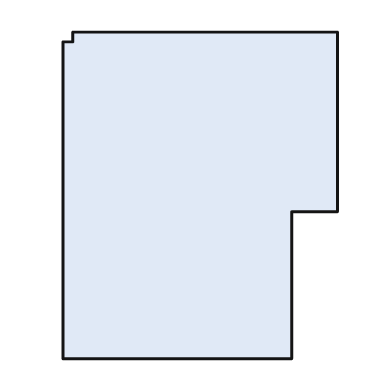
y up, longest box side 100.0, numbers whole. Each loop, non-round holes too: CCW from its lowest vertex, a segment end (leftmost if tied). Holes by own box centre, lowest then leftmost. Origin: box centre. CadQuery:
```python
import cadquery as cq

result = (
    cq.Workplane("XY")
    .moveTo(-42.0, -50.0)
    .lineTo(28.0, -50.0)
    .lineTo(28.0, -5.0)
    .lineTo(42.0, -5.0)
    .lineTo(42.0, 50.0)
    .lineTo(-39.0, 50.0)
    .lineTo(-39.0, 47.0)
    .lineTo(-42.0, 47.0)
    .close()
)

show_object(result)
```